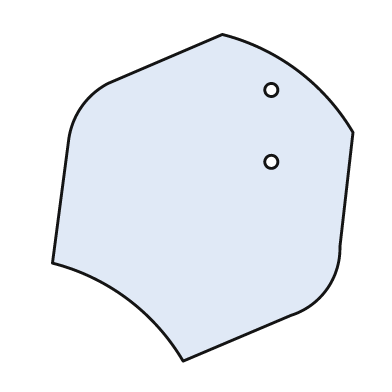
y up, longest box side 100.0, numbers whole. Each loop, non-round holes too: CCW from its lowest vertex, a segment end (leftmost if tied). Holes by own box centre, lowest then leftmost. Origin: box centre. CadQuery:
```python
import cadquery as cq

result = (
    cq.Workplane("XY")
    .moveTo(-6.0, -50.0)
    .lineTo(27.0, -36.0)
    .threePointArc((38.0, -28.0), (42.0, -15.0))
    .lineTo(46.0, 20.0)
    .threePointArc((29.0, 39.0), (6.0, 50.0))
    .lineTo(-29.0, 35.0)
    .threePointArc((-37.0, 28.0), (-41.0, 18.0))
    .lineTo(-46.0, -20.0)
    .threePointArc((-23.0, -31.0), (-6.0, -50.0))
    .close()
    .moveTo(21.0, 11.0)
    .circle(2.0)
    .moveTo(21.0, 33.0)
    .circle(2.0)
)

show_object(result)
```